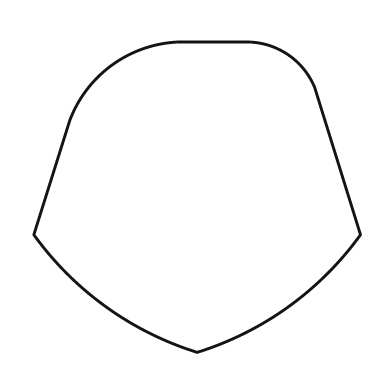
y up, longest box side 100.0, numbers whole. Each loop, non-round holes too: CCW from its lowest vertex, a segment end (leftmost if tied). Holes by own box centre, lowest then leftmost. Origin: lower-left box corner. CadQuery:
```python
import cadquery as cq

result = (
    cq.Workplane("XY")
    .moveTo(50.0, 0.0)
    .threePointArc((78.0, 14.0), (100.0, 36.0))
    .lineTo(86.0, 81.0)
    .threePointArc((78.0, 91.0), (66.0, 95.0))
    .lineTo(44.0, 95.0)
    .threePointArc((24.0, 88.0), (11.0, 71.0))
    .lineTo(0.0, 36.0)
    .threePointArc((22.0, 14.0), (50.0, 0.0))
    .close()
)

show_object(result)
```